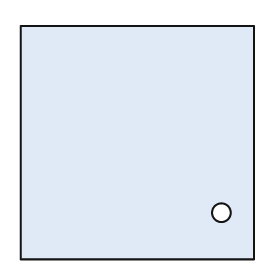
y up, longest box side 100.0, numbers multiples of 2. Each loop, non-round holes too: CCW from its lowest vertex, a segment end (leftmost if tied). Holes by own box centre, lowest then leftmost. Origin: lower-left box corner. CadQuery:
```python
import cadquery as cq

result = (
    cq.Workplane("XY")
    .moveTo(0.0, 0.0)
    .lineTo(100.0, 0.0)
    .lineTo(100.0, 100.0)
    .lineTo(0.0, 100.0)
    .close()
    .moveTo(86.0, 20.0)
    .circle(4.0)
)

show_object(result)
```